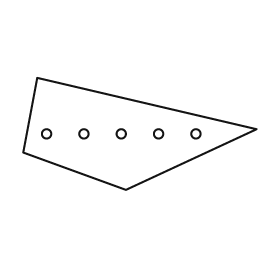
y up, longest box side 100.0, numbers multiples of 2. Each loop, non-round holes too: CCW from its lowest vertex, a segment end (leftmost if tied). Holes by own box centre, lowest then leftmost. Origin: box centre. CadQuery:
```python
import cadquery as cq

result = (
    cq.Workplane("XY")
    .moveTo(-6.0, -24.0)
    .lineTo(50.0, 2.0)
    .lineTo(-44.0, 24.0)
    .lineTo(-50.0, -8.0)
    .close()
    .moveTo(-40.0, 0.0)
    .circle(2.0)
    .moveTo(-24.0, 0.0)
    .circle(2.0)
    .moveTo(-8.0, 0.0)
    .circle(2.0)
    .moveTo(8.0, 0.0)
    .circle(2.0)
    .moveTo(24.0, 0.0)
    .circle(2.0)
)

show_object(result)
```